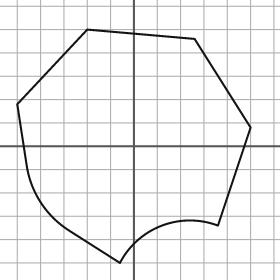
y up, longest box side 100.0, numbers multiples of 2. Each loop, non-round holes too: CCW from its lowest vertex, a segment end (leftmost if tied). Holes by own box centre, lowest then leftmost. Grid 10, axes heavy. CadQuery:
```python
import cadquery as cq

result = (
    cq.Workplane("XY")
    .moveTo(-6.0, -50.0)
    .threePointArc((12.0, -34.0), (36.0, -34.0))
    .lineTo(50.0, 8.0)
    .lineTo(26.0, 46.0)
    .lineTo(-20.0, 50.0)
    .lineTo(-50.0, 18.0)
    .lineTo(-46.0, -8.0)
    .threePointArc((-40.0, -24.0), (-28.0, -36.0))
    .close()
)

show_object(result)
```